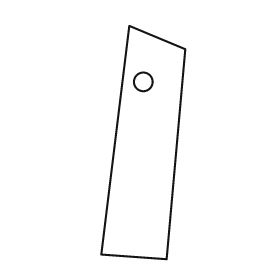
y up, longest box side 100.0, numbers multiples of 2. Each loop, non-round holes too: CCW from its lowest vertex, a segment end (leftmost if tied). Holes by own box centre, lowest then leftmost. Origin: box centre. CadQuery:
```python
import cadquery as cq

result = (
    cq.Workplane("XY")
    .moveTo(10.0, -50.0)
    .lineTo(18.0, 40.0)
    .lineTo(-6.0, 50.0)
    .lineTo(-18.0, -48.0)
    .close()
    .moveTo(0.0, 26.0)
    .circle(4.0)
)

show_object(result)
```